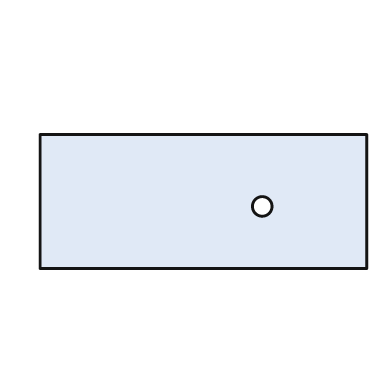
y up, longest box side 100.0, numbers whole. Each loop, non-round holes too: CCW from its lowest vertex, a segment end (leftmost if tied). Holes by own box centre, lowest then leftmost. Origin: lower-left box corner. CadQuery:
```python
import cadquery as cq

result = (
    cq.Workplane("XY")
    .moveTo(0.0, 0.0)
    .lineTo(100.0, 0.0)
    .lineTo(100.0, 41.0)
    .lineTo(0.0, 41.0)
    .close()
    .moveTo(68.0, 19.0)
    .circle(3.0)
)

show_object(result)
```